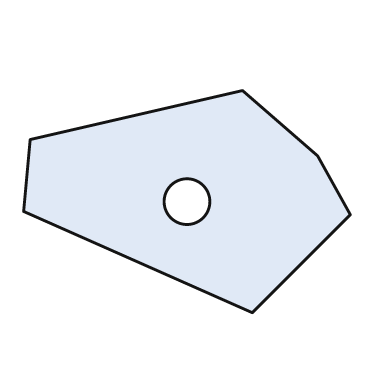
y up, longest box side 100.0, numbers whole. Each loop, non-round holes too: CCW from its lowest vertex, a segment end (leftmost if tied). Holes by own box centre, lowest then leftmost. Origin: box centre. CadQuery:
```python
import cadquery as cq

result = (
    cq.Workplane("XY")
    .moveTo(20.0, -34.0)
    .lineTo(50.0, -4.0)
    .lineTo(40.0, 14.0)
    .lineTo(17.0, 34.0)
    .lineTo(-48.0, 19.0)
    .lineTo(-50.0, -3.0)
    .close()
    .moveTo(0.0, 0.0)
    .circle(7.0)
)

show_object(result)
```